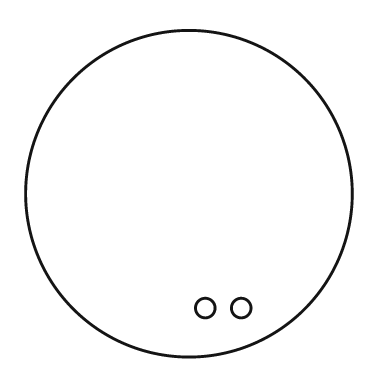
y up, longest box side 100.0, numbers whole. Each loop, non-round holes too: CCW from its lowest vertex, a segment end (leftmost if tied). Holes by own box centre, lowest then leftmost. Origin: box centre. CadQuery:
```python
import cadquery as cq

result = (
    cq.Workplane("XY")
    .moveTo(0.0, 0.0)
    .circle(50.0)
    .moveTo(5.0, -35.0)
    .circle(3.0)
    .moveTo(16.0, -35.0)
    .circle(3.0)
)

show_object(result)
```